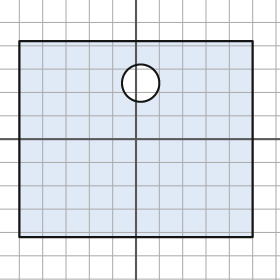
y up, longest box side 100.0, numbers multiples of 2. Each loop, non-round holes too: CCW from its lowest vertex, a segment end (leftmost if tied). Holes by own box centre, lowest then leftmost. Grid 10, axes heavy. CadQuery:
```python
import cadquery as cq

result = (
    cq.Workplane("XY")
    .moveTo(-50.0, -42.0)
    .lineTo(50.0, -42.0)
    .lineTo(50.0, 42.0)
    .lineTo(-50.0, 42.0)
    .close()
    .moveTo(2.0, 24.0)
    .circle(8.0)
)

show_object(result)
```